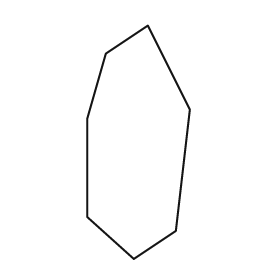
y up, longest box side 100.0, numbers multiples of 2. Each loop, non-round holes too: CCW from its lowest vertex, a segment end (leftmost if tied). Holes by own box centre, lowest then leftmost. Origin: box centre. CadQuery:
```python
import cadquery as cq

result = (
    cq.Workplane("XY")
    .moveTo(-2.0, -50.0)
    .lineTo(16.0, -38.0)
    .lineTo(22.0, 14.0)
    .lineTo(4.0, 50.0)
    .lineTo(-14.0, 38.0)
    .lineTo(-22.0, 10.0)
    .lineTo(-22.0, -32.0)
    .close()
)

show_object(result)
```